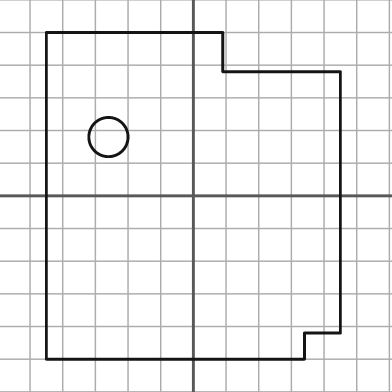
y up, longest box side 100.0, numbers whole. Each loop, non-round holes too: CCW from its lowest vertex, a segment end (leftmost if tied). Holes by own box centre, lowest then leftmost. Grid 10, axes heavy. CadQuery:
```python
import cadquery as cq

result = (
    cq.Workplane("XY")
    .moveTo(-45.0, -50.0)
    .lineTo(34.0, -50.0)
    .lineTo(34.0, -42.0)
    .lineTo(45.0, -42.0)
    .lineTo(45.0, 38.0)
    .lineTo(9.0, 38.0)
    .lineTo(9.0, 50.0)
    .lineTo(-45.0, 50.0)
    .close()
    .moveTo(-26.0, 18.0)
    .circle(6.0)
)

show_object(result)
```